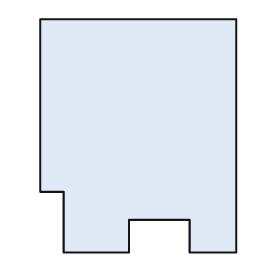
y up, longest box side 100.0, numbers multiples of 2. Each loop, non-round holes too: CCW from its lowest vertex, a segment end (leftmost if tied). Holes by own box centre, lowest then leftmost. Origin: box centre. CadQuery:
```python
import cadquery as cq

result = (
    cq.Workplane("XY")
    .moveTo(-32.0, -50.0)
    .lineTo(-4.0, -50.0)
    .lineTo(-4.0, -36.0)
    .lineTo(22.0, -36.0)
    .lineTo(22.0, -50.0)
    .lineTo(42.0, -50.0)
    .lineTo(42.0, 50.0)
    .lineTo(-42.0, 50.0)
    .lineTo(-42.0, -24.0)
    .lineTo(-32.0, -24.0)
    .close()
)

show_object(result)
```